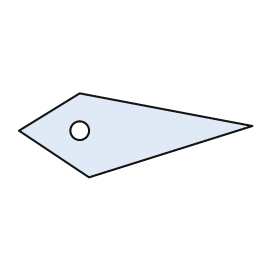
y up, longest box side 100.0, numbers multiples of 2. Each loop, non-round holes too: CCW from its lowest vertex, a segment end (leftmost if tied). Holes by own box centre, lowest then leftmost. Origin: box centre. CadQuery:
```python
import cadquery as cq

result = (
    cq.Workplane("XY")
    .moveTo(-20.0, -18.0)
    .lineTo(50.0, 4.0)
    .lineTo(-24.0, 18.0)
    .lineTo(-50.0, 2.0)
    .close()
    .moveTo(-24.0, 2.0)
    .circle(4.0)
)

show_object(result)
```